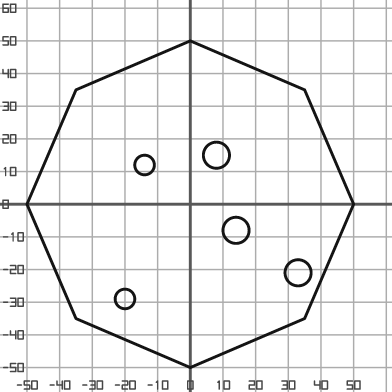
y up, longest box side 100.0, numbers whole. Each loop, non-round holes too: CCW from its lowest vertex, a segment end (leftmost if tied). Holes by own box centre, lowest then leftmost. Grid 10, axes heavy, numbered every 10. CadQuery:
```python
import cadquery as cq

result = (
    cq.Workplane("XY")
    .moveTo(0.0, -50.0)
    .lineTo(35.0, -35.0)
    .lineTo(50.0, 0.0)
    .lineTo(35.0, 35.0)
    .lineTo(0.0, 50.0)
    .lineTo(-35.0, 35.0)
    .lineTo(-50.0, 0.0)
    .lineTo(-35.0, -35.0)
    .close()
    .moveTo(-20.0, -29.0)
    .circle(3.0)
    .moveTo(33.0, -21.0)
    .circle(4.0)
    .moveTo(14.0, -8.0)
    .circle(4.0)
    .moveTo(-14.0, 12.0)
    .circle(3.0)
    .moveTo(8.0, 15.0)
    .circle(4.0)
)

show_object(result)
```